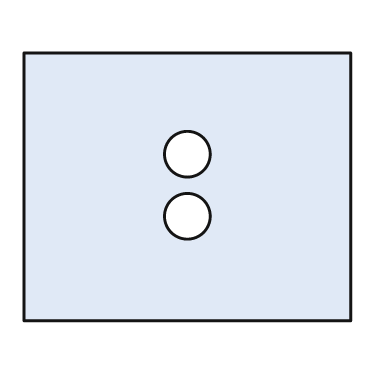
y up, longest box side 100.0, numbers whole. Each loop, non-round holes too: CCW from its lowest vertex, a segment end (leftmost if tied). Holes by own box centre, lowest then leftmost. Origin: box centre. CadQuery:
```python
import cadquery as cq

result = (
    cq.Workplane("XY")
    .moveTo(-50.0, -41.0)
    .lineTo(50.0, -41.0)
    .lineTo(50.0, 41.0)
    .lineTo(-50.0, 41.0)
    .close()
    .moveTo(0.0, -9.0)
    .circle(7.0)
    .moveTo(0.0, 10.0)
    .circle(7.0)
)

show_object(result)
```